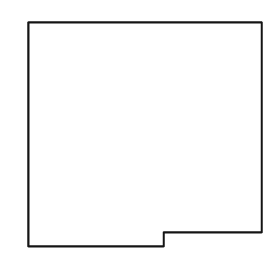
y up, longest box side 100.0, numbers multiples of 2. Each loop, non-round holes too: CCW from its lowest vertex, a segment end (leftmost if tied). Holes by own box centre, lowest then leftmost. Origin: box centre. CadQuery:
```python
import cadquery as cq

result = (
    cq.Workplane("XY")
    .moveTo(-50.0, -48.0)
    .lineTo(8.0, -48.0)
    .lineTo(8.0, -42.0)
    .lineTo(50.0, -42.0)
    .lineTo(50.0, 48.0)
    .lineTo(-50.0, 48.0)
    .close()
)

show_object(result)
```